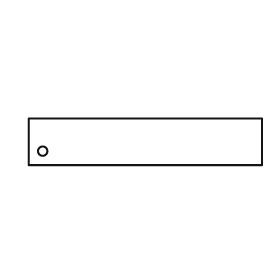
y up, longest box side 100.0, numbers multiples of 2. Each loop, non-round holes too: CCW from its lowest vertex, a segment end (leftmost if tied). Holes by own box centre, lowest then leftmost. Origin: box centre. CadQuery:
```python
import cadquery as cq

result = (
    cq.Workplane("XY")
    .moveTo(-50.0, -10.0)
    .lineTo(50.0, -10.0)
    .lineTo(50.0, 10.0)
    .lineTo(-50.0, 10.0)
    .close()
    .moveTo(-44.0, -4.0)
    .circle(2.0)
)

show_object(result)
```